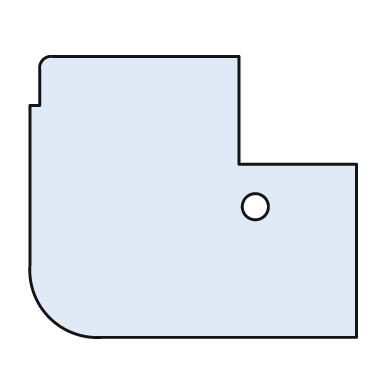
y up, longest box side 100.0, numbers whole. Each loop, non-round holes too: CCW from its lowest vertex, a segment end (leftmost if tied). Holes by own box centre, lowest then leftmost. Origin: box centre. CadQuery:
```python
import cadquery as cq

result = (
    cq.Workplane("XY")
    .moveTo(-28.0, -43.0)
    .lineTo(50.0, -43.0)
    .lineTo(50.0, 10.0)
    .lineTo(14.0, 10.0)
    .lineTo(14.0, 43.0)
    .lineTo(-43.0, 43.0)
    .threePointArc((-46.0, 42.0), (-47.0, 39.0))
    .lineTo(-47.0, 28.0)
    .lineTo(-50.0, 28.0)
    .lineTo(-50.0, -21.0)
    .threePointArc((-44.0, -37.0), (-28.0, -43.0))
    .close()
    .moveTo(19.0, -3.0)
    .circle(4.0)
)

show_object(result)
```